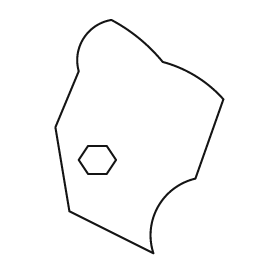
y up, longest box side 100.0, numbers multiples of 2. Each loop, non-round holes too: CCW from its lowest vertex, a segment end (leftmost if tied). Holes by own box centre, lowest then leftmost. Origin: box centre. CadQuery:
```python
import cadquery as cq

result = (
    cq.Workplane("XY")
    .moveTo(6.0, -50.0)
    .threePointArc((8.0, -30.0), (24.0, -18.0))
    .lineTo(36.0, 16.0)
    .threePointArc((24.0, 26.0), (10.0, 32.0))
    .threePointArc((0.0, 42.0), (-12.0, 50.0))
    .threePointArc((-24.0, 42.0), (-26.0, 28.0))
    .lineTo(-36.0, 4.0)
    .lineTo(-30.0, -32.0)
    .close()
    .moveTo(-22.0, -16.0)
    .lineTo(-14.0, -16.0)
    .lineTo(-10.0, -10.0)
    .lineTo(-14.0, -4.0)
    .lineTo(-22.0, -4.0)
    .lineTo(-26.0, -10.0)
    .close()
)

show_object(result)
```